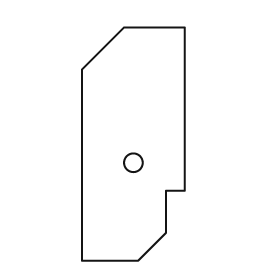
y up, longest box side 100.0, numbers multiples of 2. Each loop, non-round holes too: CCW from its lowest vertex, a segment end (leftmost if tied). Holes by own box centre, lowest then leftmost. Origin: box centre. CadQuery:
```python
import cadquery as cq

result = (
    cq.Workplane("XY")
    .moveTo(-22.0, -50.0)
    .lineTo(2.0, -50.0)
    .lineTo(14.0, -38.0)
    .lineTo(14.0, -20.0)
    .lineTo(22.0, -20.0)
    .lineTo(22.0, 50.0)
    .lineTo(-4.0, 50.0)
    .lineTo(-22.0, 32.0)
    .close()
    .moveTo(0.0, -8.0)
    .circle(4.0)
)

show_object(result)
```